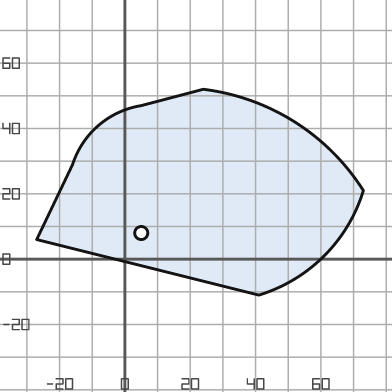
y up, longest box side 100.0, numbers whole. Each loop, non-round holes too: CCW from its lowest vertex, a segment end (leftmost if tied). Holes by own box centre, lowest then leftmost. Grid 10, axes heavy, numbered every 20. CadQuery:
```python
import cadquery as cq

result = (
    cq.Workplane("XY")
    .moveTo(41.0, -11.0)
    .threePointArc((61.0, 1.0), (73.0, 21.0))
    .threePointArc((52.0, 42.0), (24.0, 52.0))
    .lineTo(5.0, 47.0)
    .threePointArc((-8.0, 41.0), (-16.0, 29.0))
    .lineTo(-27.0, 6.0)
    .close()
    .moveTo(5.0, 8.0)
    .circle(2.0)
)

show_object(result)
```